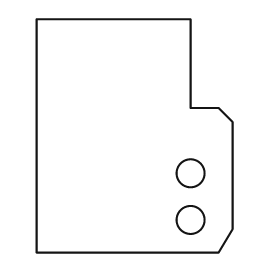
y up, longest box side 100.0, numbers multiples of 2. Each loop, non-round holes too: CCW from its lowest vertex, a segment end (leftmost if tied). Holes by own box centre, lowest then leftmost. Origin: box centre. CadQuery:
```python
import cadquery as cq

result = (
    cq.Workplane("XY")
    .moveTo(-42.0, -50.0)
    .lineTo(36.0, -50.0)
    .lineTo(42.0, -40.0)
    .lineTo(42.0, 6.0)
    .lineTo(36.0, 12.0)
    .lineTo(24.0, 12.0)
    .lineTo(24.0, 50.0)
    .lineTo(-42.0, 50.0)
    .close()
    .moveTo(24.0, -36.0)
    .circle(6.0)
    .moveTo(24.0, -16.0)
    .circle(6.0)
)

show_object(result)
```